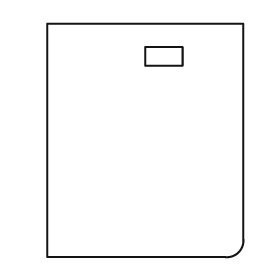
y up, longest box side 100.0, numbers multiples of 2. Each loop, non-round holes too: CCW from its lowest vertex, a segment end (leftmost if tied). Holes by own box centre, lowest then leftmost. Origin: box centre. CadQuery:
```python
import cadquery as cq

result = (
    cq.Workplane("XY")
    .moveTo(-42.0, -50.0)
    .lineTo(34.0, -50.0)
    .threePointArc((40.0, -48.0), (42.0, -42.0))
    .lineTo(42.0, 50.0)
    .lineTo(-42.0, 50.0)
    .close()
    .moveTo(0.0, 32.0)
    .lineTo(16.0, 32.0)
    .lineTo(16.0, 40.0)
    .lineTo(0.0, 40.0)
    .close()
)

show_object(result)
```